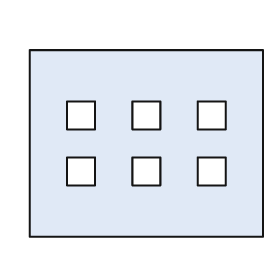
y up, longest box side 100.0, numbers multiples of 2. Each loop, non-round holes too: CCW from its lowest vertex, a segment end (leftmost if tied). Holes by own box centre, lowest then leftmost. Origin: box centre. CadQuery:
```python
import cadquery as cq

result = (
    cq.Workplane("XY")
    .moveTo(-50.0, -40.0)
    .lineTo(50.0, -40.0)
    .lineTo(50.0, 40.0)
    .lineTo(-50.0, 40.0)
    .close()
    .moveTo(-34.0, -18.0)
    .lineTo(-22.0, -18.0)
    .lineTo(-22.0, -6.0)
    .lineTo(-34.0, -6.0)
    .close()
    .moveTo(-6.0, -18.0)
    .lineTo(6.0, -18.0)
    .lineTo(6.0, -6.0)
    .lineTo(-6.0, -6.0)
    .close()
    .moveTo(22.0, -18.0)
    .lineTo(34.0, -18.0)
    .lineTo(34.0, -6.0)
    .lineTo(22.0, -6.0)
    .close()
    .moveTo(-34.0, 6.0)
    .lineTo(-22.0, 6.0)
    .lineTo(-22.0, 18.0)
    .lineTo(-34.0, 18.0)
    .close()
    .moveTo(-6.0, 6.0)
    .lineTo(6.0, 6.0)
    .lineTo(6.0, 18.0)
    .lineTo(-6.0, 18.0)
    .close()
    .moveTo(22.0, 6.0)
    .lineTo(34.0, 6.0)
    .lineTo(34.0, 18.0)
    .lineTo(22.0, 18.0)
    .close()
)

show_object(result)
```